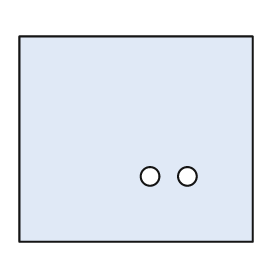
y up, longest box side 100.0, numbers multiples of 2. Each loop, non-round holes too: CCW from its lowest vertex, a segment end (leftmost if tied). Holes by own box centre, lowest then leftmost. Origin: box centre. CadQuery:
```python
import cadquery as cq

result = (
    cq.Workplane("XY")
    .moveTo(-50.0, -44.0)
    .lineTo(50.0, -44.0)
    .lineTo(50.0, 44.0)
    .lineTo(-50.0, 44.0)
    .close()
    .moveTo(6.0, -16.0)
    .circle(4.0)
    .moveTo(22.0, -16.0)
    .circle(4.0)
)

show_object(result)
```